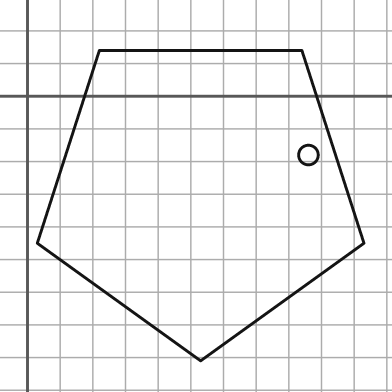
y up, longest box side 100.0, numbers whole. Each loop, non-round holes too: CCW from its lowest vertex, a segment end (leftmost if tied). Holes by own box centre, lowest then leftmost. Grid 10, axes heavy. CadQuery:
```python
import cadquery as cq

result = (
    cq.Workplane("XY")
    .moveTo(53.0, -81.0)
    .lineTo(103.0, -45.0)
    .lineTo(84.0, 14.0)
    .lineTo(22.0, 14.0)
    .lineTo(3.0, -45.0)
    .close()
    .moveTo(86.0, -18.0)
    .circle(3.0)
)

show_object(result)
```